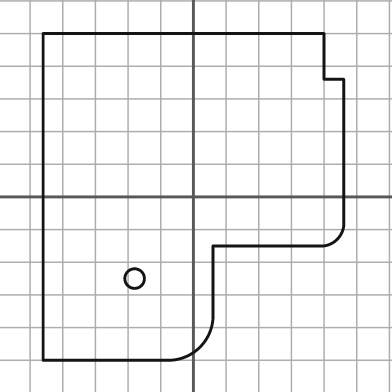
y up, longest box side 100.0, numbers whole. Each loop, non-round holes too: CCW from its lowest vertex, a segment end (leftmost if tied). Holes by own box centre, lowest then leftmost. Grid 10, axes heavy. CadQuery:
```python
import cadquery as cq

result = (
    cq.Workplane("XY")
    .moveTo(-46.0, -50.0)
    .lineTo(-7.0, -50.0)
    .threePointArc((2.0, -46.0), (6.0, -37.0))
    .lineTo(6.0, -15.0)
    .lineTo(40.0, -15.0)
    .threePointArc((44.0, -13.0), (46.0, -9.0))
    .lineTo(46.0, 36.0)
    .lineTo(40.0, 36.0)
    .lineTo(40.0, 50.0)
    .lineTo(-46.0, 50.0)
    .close()
    .moveTo(-18.0, -25.0)
    .circle(3.0)
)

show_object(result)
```